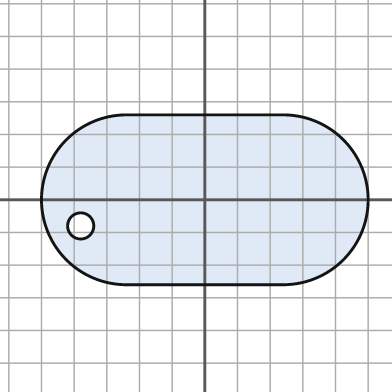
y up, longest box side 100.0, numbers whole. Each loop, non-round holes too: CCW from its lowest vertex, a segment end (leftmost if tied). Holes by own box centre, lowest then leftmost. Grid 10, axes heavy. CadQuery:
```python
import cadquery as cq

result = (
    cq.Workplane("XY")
    .moveTo(-24.0, -26.0)
    .lineTo(24.0, -26.0)
    .threePointArc((50.0, 0.0), (24.0, 26.0))
    .lineTo(-24.0, 26.0)
    .threePointArc((-50.0, 0.0), (-24.0, -26.0))
    .close()
    .moveTo(-38.0, -8.0)
    .circle(4.0)
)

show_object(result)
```